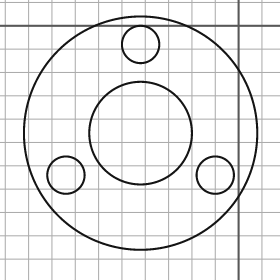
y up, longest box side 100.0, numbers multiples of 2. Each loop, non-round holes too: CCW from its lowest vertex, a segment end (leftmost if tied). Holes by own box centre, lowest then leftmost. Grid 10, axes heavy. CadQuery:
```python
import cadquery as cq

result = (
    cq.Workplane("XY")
    .moveTo(-42.0, -46.0)
    .circle(50.0)
    .moveTo(-74.0, -64.0)
    .circle(8.0)
    .moveTo(-10.0, -64.0)
    .circle(8.0)
    .moveTo(-42.0, -46.0)
    .circle(22.0)
    .moveTo(-42.0, -8.0)
    .circle(8.0)
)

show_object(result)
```